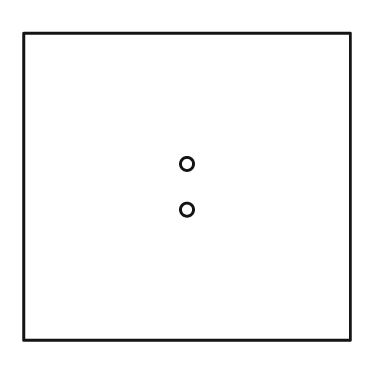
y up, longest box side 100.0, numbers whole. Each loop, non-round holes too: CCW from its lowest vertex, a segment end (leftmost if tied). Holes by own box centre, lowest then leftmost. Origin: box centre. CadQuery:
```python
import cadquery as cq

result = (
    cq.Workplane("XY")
    .moveTo(-50.0, -47.0)
    .lineTo(50.0, -47.0)
    .lineTo(50.0, 47.0)
    .lineTo(-50.0, 47.0)
    .close()
    .moveTo(0.0, -7.0)
    .circle(2.0)
    .moveTo(0.0, 7.0)
    .circle(2.0)
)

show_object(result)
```